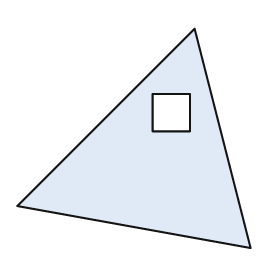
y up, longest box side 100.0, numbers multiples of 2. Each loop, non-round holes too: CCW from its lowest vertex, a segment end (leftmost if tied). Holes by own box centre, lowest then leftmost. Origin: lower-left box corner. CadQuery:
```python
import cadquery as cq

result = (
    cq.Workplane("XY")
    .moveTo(100.0, 0.0)
    .lineTo(76.0, 94.0)
    .lineTo(0.0, 18.0)
    .close()
    .moveTo(58.0, 50.0)
    .lineTo(74.0, 50.0)
    .lineTo(74.0, 66.0)
    .lineTo(58.0, 66.0)
    .close()
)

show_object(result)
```